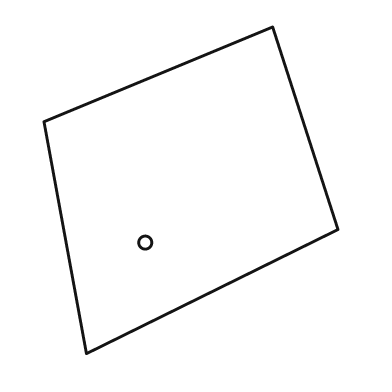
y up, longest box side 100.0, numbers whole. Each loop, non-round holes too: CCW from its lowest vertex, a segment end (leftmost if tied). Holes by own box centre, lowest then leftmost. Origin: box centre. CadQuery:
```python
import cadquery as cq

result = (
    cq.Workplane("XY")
    .moveTo(-32.0, -50.0)
    .lineTo(45.0, -12.0)
    .lineTo(25.0, 50.0)
    .lineTo(-45.0, 21.0)
    .close()
    .moveTo(-14.0, -16.0)
    .circle(2.0)
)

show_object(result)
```